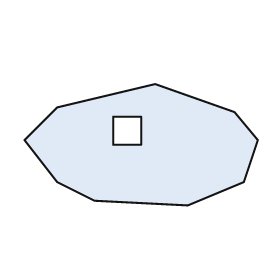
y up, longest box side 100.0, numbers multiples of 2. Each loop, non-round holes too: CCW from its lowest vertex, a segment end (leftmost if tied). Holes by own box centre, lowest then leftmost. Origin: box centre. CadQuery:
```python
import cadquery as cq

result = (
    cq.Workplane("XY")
    .moveTo(20.0, -26.0)
    .lineTo(44.0, -16.0)
    .lineTo(50.0, 2.0)
    .lineTo(40.0, 14.0)
    .lineTo(6.0, 26.0)
    .lineTo(-36.0, 16.0)
    .lineTo(-50.0, 2.0)
    .lineTo(-36.0, -16.0)
    .lineTo(-20.0, -24.0)
    .close()
    .moveTo(-12.0, 0.0)
    .lineTo(0.0, 0.0)
    .lineTo(0.0, 12.0)
    .lineTo(-12.0, 12.0)
    .close()
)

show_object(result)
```